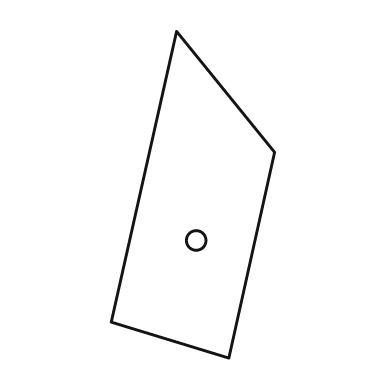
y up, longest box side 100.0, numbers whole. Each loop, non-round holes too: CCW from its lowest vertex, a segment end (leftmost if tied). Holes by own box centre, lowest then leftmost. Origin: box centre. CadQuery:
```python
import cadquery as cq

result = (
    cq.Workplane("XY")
    .moveTo(11.0, -50.0)
    .lineTo(25.0, 13.0)
    .lineTo(-5.0, 50.0)
    .lineTo(-25.0, -39.0)
    .close()
    .moveTo(1.0, -14.0)
    .circle(3.0)
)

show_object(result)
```